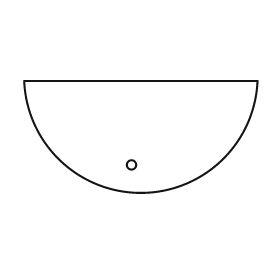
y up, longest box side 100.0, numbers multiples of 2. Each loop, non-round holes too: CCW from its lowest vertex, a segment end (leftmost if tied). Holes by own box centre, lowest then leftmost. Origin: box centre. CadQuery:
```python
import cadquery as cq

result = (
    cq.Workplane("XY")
    .moveTo(-50.0, 24.0)
    .threePointArc((0.0, -24.0), (50.0, 24.0))
    .close()
    .moveTo(-4.0, -12.0)
    .circle(2.0)
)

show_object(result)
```